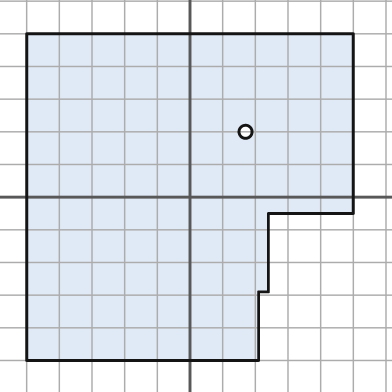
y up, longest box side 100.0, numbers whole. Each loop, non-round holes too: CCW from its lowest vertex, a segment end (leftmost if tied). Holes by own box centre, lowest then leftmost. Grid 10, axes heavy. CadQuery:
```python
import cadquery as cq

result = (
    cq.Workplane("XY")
    .moveTo(-50.0, -50.0)
    .lineTo(21.0, -50.0)
    .lineTo(21.0, -29.0)
    .lineTo(24.0, -29.0)
    .lineTo(24.0, -5.0)
    .lineTo(50.0, -5.0)
    .lineTo(50.0, 50.0)
    .lineTo(-50.0, 50.0)
    .close()
    .moveTo(17.0, 20.0)
    .circle(2.0)
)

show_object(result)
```